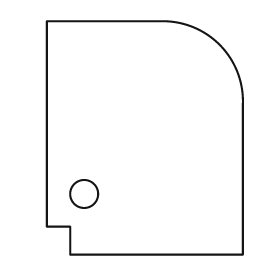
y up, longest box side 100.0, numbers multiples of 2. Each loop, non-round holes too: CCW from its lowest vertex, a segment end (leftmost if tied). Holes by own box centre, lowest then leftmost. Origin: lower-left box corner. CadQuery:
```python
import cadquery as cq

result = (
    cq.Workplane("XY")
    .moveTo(10.0, 0.0)
    .lineTo(84.0, 0.0)
    .lineTo(84.0, 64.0)
    .threePointArc((74.0, 90.0), (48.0, 100.0))
    .lineTo(0.0, 100.0)
    .lineTo(0.0, 12.0)
    .lineTo(10.0, 12.0)
    .close()
    .moveTo(16.0, 26.0)
    .circle(6.0)
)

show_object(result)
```